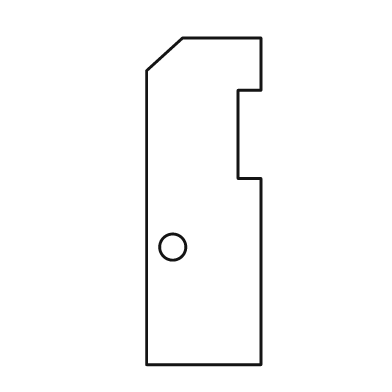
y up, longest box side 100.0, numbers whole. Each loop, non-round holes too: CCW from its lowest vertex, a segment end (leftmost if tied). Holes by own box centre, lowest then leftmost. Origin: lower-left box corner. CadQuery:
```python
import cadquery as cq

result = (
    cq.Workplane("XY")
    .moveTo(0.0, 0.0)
    .lineTo(35.0, 0.0)
    .lineTo(35.0, 57.0)
    .lineTo(28.0, 57.0)
    .lineTo(28.0, 84.0)
    .lineTo(35.0, 84.0)
    .lineTo(35.0, 100.0)
    .lineTo(11.0, 100.0)
    .lineTo(0.0, 90.0)
    .close()
    .moveTo(8.0, 36.0)
    .circle(4.0)
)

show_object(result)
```